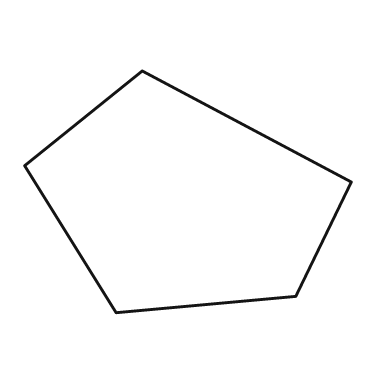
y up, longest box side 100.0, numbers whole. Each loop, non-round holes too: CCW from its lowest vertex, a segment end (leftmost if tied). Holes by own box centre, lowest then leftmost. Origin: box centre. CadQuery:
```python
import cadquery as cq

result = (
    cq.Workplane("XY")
    .moveTo(-22.0, -37.0)
    .lineTo(33.0, -32.0)
    .lineTo(50.0, 3.0)
    .lineTo(-14.0, 37.0)
    .lineTo(-50.0, 8.0)
    .close()
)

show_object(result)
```